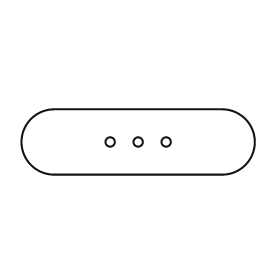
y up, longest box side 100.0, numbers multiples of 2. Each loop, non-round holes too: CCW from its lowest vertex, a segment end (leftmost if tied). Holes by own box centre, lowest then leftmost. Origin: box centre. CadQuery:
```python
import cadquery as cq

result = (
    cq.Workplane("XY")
    .moveTo(-36.0, -14.0)
    .lineTo(36.0, -14.0)
    .threePointArc((50.0, 0.0), (36.0, 14.0))
    .lineTo(-36.0, 14.0)
    .threePointArc((-50.0, 0.0), (-36.0, -14.0))
    .close()
    .moveTo(-12.0, 0.0)
    .circle(2.0)
    .moveTo(0.0, 0.0)
    .circle(2.0)
    .moveTo(12.0, 0.0)
    .circle(2.0)
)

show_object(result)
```